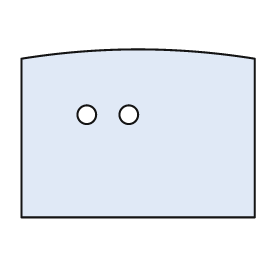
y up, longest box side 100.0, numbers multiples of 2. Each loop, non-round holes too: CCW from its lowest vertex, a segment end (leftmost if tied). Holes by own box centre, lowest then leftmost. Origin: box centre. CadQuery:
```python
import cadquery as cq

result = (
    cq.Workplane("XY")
    .moveTo(-50.0, -36.0)
    .lineTo(50.0, -36.0)
    .lineTo(50.0, 32.0)
    .threePointArc((0.0, 36.0), (-50.0, 32.0))
    .close()
    .moveTo(-22.0, 8.0)
    .circle(4.0)
    .moveTo(-4.0, 8.0)
    .circle(4.0)
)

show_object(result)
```